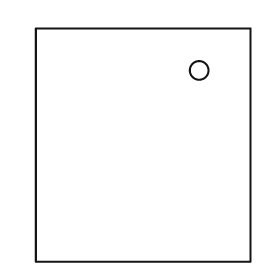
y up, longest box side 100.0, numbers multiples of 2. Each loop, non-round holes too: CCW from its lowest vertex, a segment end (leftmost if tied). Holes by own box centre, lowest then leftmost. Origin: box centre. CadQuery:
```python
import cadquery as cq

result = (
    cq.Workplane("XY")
    .moveTo(-46.0, -50.0)
    .lineTo(46.0, -50.0)
    .lineTo(46.0, 50.0)
    .lineTo(-46.0, 50.0)
    .close()
    .moveTo(24.0, 32.0)
    .circle(4.0)
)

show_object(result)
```